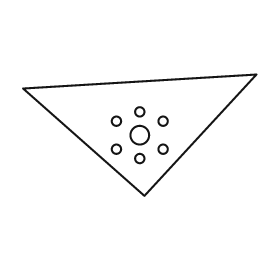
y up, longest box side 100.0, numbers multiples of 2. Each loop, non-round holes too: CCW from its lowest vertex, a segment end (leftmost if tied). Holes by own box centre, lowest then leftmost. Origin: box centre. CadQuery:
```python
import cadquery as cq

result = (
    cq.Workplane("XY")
    .moveTo(2.0, -26.0)
    .lineTo(50.0, 26.0)
    .lineTo(-50.0, 20.0)
    .close()
    .moveTo(0.0, -10.0)
    .circle(2.0)
    .moveTo(-10.0, -6.0)
    .circle(2.0)
    .moveTo(10.0, -6.0)
    .circle(2.0)
    .moveTo(0.0, 0.0)
    .circle(4.0)
    .moveTo(-10.0, 6.0)
    .circle(2.0)
    .moveTo(10.0, 6.0)
    .circle(2.0)
    .moveTo(0.0, 10.0)
    .circle(2.0)
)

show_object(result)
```